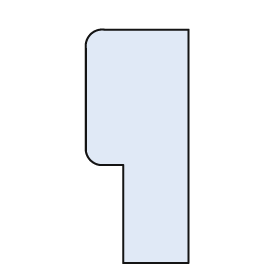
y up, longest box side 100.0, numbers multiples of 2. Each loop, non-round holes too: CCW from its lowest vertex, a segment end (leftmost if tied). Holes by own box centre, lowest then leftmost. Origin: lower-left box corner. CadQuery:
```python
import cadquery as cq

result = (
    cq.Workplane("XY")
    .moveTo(16.0, 0.0)
    .lineTo(44.0, 0.0)
    .lineTo(44.0, 100.0)
    .lineTo(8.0, 100.0)
    .threePointArc((2.0, 98.0), (0.0, 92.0))
    .lineTo(0.0, 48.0)
    .threePointArc((2.0, 44.0), (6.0, 42.0))
    .lineTo(16.0, 42.0)
    .close()
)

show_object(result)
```